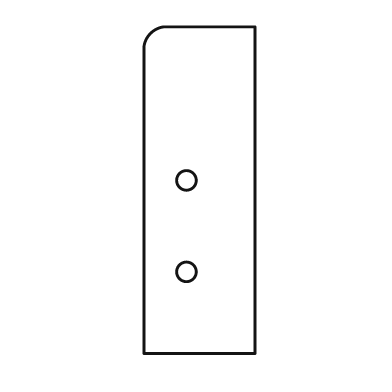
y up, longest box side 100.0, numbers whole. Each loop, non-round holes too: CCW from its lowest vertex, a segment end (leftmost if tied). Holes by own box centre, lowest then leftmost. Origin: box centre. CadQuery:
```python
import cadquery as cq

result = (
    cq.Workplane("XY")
    .moveTo(-17.0, -50.0)
    .lineTo(17.0, -50.0)
    .lineTo(17.0, 50.0)
    .lineTo(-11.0, 50.0)
    .threePointArc((-15.0, 48.0), (-17.0, 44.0))
    .close()
    .moveTo(-4.0, -25.0)
    .circle(3.0)
    .moveTo(-4.0, 3.0)
    .circle(3.0)
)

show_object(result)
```